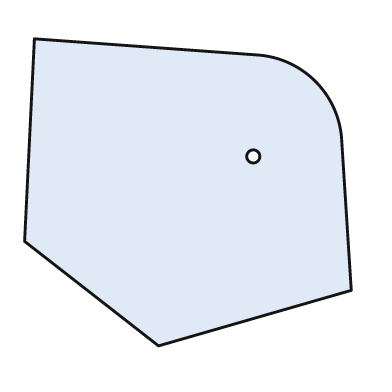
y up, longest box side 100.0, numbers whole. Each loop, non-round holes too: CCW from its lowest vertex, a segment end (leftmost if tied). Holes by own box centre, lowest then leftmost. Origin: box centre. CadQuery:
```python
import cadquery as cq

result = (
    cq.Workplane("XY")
    .moveTo(-9.0, -47.0)
    .lineTo(50.0, -30.0)
    .lineTo(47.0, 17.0)
    .threePointArc((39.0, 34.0), (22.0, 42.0))
    .lineTo(-47.0, 47.0)
    .lineTo(-50.0, -15.0)
    .close()
    .moveTo(20.0, 11.0)
    .circle(2.0)
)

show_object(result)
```